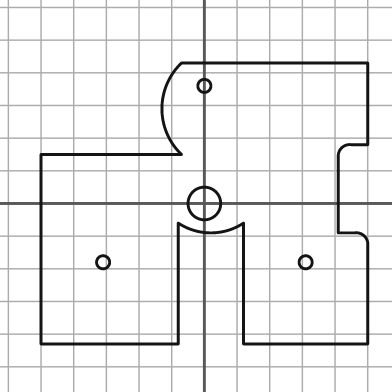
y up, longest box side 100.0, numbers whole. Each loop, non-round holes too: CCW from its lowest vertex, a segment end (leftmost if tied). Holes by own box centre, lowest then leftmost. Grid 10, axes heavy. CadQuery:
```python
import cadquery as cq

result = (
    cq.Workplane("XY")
    .moveTo(-50.0, -43.0)
    .lineTo(-8.0, -43.0)
    .lineTo(-8.0, -6.0)
    .threePointArc((2.0, -9.0), (12.0, -6.0))
    .lineTo(12.0, -43.0)
    .lineTo(50.0, -43.0)
    .lineTo(50.0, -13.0)
    .threePointArc((49.0, -10.0), (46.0, -9.0))
    .lineTo(41.0, -9.0)
    .lineTo(41.0, 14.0)
    .threePointArc((42.0, 17.0), (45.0, 18.0))
    .lineTo(50.0, 18.0)
    .lineTo(50.0, 43.0)
    .lineTo(-7.0, 43.0)
    .threePointArc((-13.0, 29.0), (-7.0, 15.0))
    .lineTo(-50.0, 15.0)
    .close()
    .moveTo(-31.0, -18.0)
    .circle(2.0)
    .moveTo(31.0, -18.0)
    .circle(2.0)
    .moveTo(0.0, 0.0)
    .circle(5.0)
    .moveTo(0.0, 36.0)
    .circle(2.0)
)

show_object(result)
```